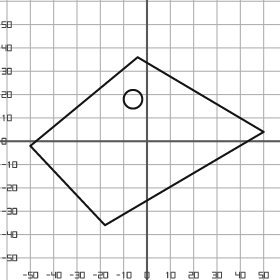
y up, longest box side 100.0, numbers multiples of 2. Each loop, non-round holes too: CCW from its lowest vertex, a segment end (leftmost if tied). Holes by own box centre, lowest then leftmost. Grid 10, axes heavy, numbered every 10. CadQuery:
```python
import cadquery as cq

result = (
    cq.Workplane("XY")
    .moveTo(-18.0, -36.0)
    .lineTo(50.0, 4.0)
    .lineTo(-4.0, 36.0)
    .lineTo(-50.0, -2.0)
    .close()
    .moveTo(-6.0, 18.0)
    .circle(4.0)
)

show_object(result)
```